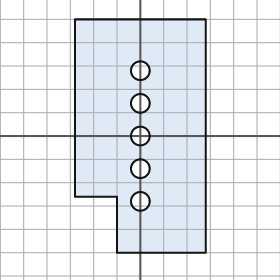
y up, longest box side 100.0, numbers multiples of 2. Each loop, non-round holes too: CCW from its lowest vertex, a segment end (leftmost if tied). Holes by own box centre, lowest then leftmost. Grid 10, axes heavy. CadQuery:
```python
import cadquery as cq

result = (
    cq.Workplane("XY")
    .moveTo(-10.0, -50.0)
    .lineTo(28.0, -50.0)
    .lineTo(28.0, 50.0)
    .lineTo(-28.0, 50.0)
    .lineTo(-28.0, -26.0)
    .lineTo(-10.0, -26.0)
    .close()
    .moveTo(0.0, -28.0)
    .circle(4.0)
    .moveTo(0.0, -14.0)
    .circle(4.0)
    .moveTo(0.0, 0.0)
    .circle(4.0)
    .moveTo(0.0, 14.0)
    .circle(4.0)
    .moveTo(0.0, 28.0)
    .circle(4.0)
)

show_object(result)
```